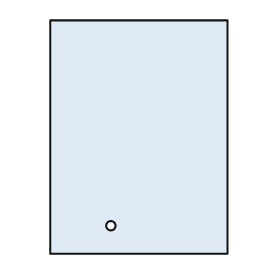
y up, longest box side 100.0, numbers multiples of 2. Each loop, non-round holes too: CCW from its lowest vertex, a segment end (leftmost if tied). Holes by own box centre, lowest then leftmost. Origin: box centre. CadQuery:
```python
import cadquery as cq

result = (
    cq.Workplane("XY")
    .moveTo(-38.0, -50.0)
    .lineTo(38.0, -50.0)
    .lineTo(38.0, 50.0)
    .lineTo(-38.0, 50.0)
    .close()
    .moveTo(-12.0, -38.0)
    .circle(2.0)
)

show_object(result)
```